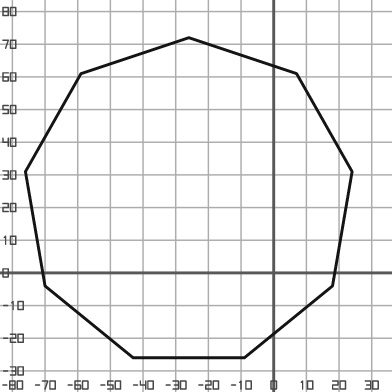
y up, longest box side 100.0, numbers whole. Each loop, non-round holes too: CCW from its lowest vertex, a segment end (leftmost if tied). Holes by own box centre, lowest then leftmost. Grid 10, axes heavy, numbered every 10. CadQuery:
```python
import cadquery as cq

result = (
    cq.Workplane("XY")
    .moveTo(-43.0, -26.0)
    .lineTo(-9.0, -26.0)
    .lineTo(18.0, -4.0)
    .lineTo(24.0, 31.0)
    .lineTo(7.0, 61.0)
    .lineTo(-26.0, 72.0)
    .lineTo(-59.0, 61.0)
    .lineTo(-76.0, 31.0)
    .lineTo(-70.0, -4.0)
    .close()
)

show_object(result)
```